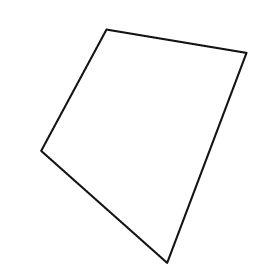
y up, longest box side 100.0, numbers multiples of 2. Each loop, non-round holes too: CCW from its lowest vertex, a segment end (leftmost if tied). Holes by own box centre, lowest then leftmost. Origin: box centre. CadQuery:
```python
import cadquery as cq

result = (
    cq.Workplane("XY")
    .moveTo(10.0, -50.0)
    .lineTo(44.0, 40.0)
    .lineTo(-16.0, 50.0)
    .lineTo(-44.0, -2.0)
    .close()
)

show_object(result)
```